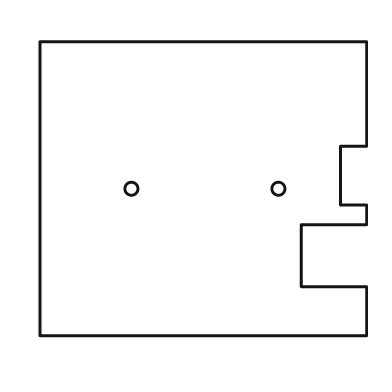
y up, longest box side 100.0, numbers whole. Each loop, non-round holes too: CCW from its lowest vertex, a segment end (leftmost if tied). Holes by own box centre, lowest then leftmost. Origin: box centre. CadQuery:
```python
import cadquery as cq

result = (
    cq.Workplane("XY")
    .moveTo(-50.0, -45.0)
    .lineTo(50.0, -45.0)
    .lineTo(50.0, -30.0)
    .lineTo(30.0, -30.0)
    .lineTo(30.0, -11.0)
    .lineTo(50.0, -11.0)
    .lineTo(50.0, -5.0)
    .lineTo(42.0, -5.0)
    .lineTo(42.0, 13.0)
    .lineTo(50.0, 13.0)
    .lineTo(50.0, 45.0)
    .lineTo(-50.0, 45.0)
    .close()
    .moveTo(-22.0, 0.0)
    .circle(2.0)
    .moveTo(23.0, 0.0)
    .circle(2.0)
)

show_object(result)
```